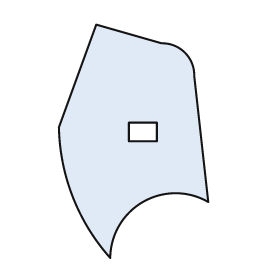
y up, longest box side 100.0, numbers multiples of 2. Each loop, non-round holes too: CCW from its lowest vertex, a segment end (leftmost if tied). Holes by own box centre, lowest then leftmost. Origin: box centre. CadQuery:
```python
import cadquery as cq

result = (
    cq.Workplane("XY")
    .moveTo(-10.0, -50.0)
    .threePointArc((4.0, -26.0), (32.0, -26.0))
    .lineTo(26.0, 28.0)
    .threePointArc((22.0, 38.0), (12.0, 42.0))
    .lineTo(-16.0, 50.0)
    .lineTo(-32.0, 6.0)
    .threePointArc((-26.0, -24.0), (-10.0, -50.0))
    .close()
    .moveTo(-2.0, 0.0)
    .lineTo(10.0, 0.0)
    .lineTo(10.0, 8.0)
    .lineTo(-2.0, 8.0)
    .close()
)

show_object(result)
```